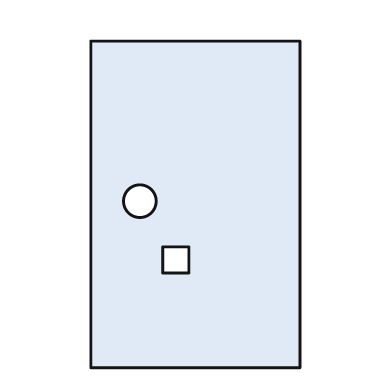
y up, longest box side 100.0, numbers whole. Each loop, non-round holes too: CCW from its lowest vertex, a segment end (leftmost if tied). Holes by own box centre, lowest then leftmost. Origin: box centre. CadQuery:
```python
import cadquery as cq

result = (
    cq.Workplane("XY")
    .moveTo(-32.0, -50.0)
    .lineTo(32.0, -50.0)
    .lineTo(32.0, 50.0)
    .lineTo(-32.0, 50.0)
    .close()
    .moveTo(-10.0, -21.0)
    .lineTo(-2.0, -21.0)
    .lineTo(-2.0, -13.0)
    .lineTo(-10.0, -13.0)
    .close()
    .moveTo(-17.0, 1.0)
    .circle(5.0)
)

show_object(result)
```